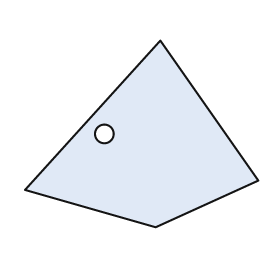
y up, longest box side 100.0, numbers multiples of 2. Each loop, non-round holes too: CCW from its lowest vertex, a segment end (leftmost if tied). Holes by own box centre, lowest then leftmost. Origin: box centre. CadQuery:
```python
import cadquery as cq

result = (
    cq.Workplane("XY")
    .moveTo(6.0, -40.0)
    .lineTo(50.0, -20.0)
    .lineTo(8.0, 40.0)
    .lineTo(-50.0, -24.0)
    .close()
    .moveTo(-16.0, 0.0)
    .circle(4.0)
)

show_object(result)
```